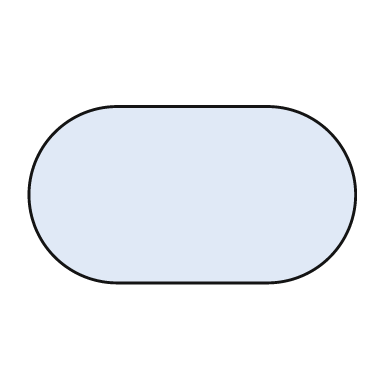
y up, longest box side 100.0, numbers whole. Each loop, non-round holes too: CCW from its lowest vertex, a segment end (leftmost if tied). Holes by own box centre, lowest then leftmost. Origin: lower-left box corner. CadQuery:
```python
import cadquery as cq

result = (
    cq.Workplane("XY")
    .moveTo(27.0, 0.0)
    .lineTo(73.0, 0.0)
    .threePointArc((100.0, 27.0), (73.0, 54.0))
    .lineTo(27.0, 54.0)
    .threePointArc((0.0, 27.0), (27.0, 0.0))
    .close()
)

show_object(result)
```